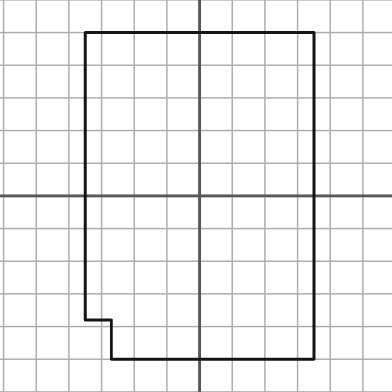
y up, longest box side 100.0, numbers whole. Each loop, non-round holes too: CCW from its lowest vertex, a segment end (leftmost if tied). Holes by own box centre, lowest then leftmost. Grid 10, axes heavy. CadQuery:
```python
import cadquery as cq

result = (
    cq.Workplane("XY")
    .moveTo(-27.0, -50.0)
    .lineTo(35.0, -50.0)
    .lineTo(35.0, 50.0)
    .lineTo(-35.0, 50.0)
    .lineTo(-35.0, -38.0)
    .lineTo(-27.0, -38.0)
    .close()
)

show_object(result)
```